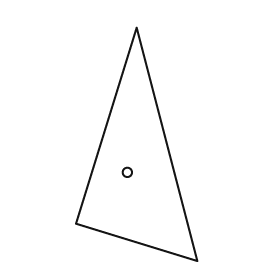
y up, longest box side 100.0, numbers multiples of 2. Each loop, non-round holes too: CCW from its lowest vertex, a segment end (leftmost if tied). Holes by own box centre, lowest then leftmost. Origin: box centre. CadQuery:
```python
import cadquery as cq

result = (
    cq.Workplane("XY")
    .moveTo(26.0, -50.0)
    .lineTo(0.0, 50.0)
    .lineTo(-26.0, -34.0)
    .close()
    .moveTo(-4.0, -12.0)
    .circle(2.0)
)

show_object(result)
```